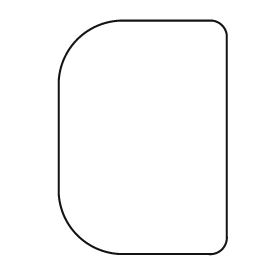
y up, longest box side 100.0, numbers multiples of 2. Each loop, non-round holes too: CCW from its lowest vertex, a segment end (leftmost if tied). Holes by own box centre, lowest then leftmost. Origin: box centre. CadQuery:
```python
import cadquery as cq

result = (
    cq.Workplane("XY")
    .moveTo(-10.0, -50.0)
    .lineTo(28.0, -50.0)
    .threePointArc((34.0, -48.0), (36.0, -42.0))
    .lineTo(36.0, 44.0)
    .threePointArc((34.0, 48.0), (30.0, 50.0))
    .lineTo(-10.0, 50.0)
    .threePointArc((-28.0, 42.0), (-36.0, 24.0))
    .lineTo(-36.0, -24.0)
    .threePointArc((-28.0, -42.0), (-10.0, -50.0))
    .close()
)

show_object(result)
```